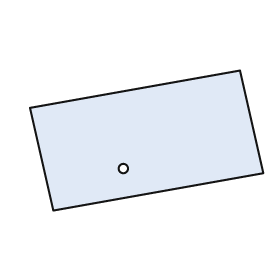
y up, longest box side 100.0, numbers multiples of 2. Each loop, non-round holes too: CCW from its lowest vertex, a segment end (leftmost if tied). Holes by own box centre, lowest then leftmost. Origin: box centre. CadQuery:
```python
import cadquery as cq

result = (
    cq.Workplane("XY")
    .moveTo(-40.0, -30.0)
    .lineTo(50.0, -14.0)
    .lineTo(40.0, 30.0)
    .lineTo(-50.0, 14.0)
    .close()
    .moveTo(-10.0, -12.0)
    .circle(2.0)
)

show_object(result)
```